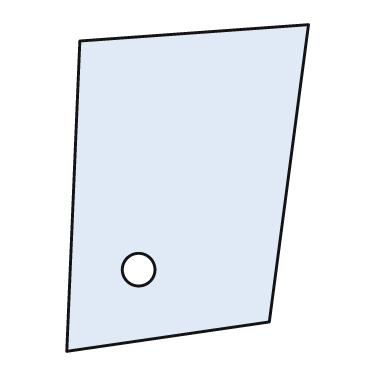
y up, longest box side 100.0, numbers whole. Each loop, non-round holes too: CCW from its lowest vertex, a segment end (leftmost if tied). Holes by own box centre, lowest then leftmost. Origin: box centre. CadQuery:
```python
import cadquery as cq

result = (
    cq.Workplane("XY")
    .moveTo(-37.0, -50.0)
    .lineTo(25.0, -41.0)
    .lineTo(37.0, 50.0)
    .lineTo(-33.0, 45.0)
    .close()
    .moveTo(-15.0, -25.0)
    .circle(5.0)
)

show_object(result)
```